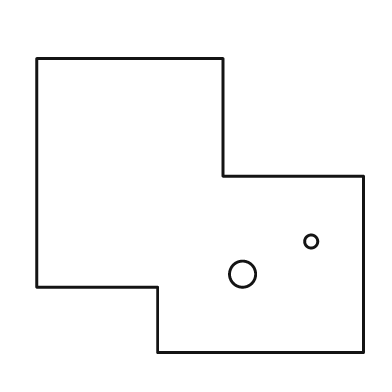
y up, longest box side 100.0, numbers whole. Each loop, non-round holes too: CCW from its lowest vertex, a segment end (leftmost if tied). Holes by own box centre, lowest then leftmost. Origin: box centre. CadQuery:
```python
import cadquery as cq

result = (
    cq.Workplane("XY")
    .moveTo(-13.0, -45.0)
    .lineTo(50.0, -45.0)
    .lineTo(50.0, 9.0)
    .lineTo(7.0, 9.0)
    .lineTo(7.0, 45.0)
    .lineTo(-50.0, 45.0)
    .lineTo(-50.0, -25.0)
    .lineTo(-13.0, -25.0)
    .close()
    .moveTo(13.0, -21.0)
    .circle(4.0)
    .moveTo(34.0, -11.0)
    .circle(2.0)
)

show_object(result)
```